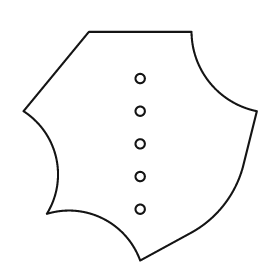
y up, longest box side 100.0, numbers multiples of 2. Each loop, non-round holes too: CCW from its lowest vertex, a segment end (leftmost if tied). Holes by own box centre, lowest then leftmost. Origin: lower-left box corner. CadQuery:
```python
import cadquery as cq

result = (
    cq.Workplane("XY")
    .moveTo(50.0, 0.0)
    .lineTo(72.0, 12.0)
    .threePointArc((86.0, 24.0), (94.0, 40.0))
    .lineTo(100.0, 64.0)
    .threePointArc((80.0, 76.0), (72.0, 98.0))
    .lineTo(28.0, 98.0)
    .lineTo(0.0, 64.0)
    .threePointArc((14.0, 44.0), (10.0, 20.0))
    .threePointArc((34.0, 18.0), (50.0, 0.0))
    .close()
    .moveTo(50.0, 22.0)
    .circle(2.0)
    .moveTo(50.0, 36.0)
    .circle(2.0)
    .moveTo(50.0, 50.0)
    .circle(2.0)
    .moveTo(50.0, 64.0)
    .circle(2.0)
    .moveTo(50.0, 78.0)
    .circle(2.0)
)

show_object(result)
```